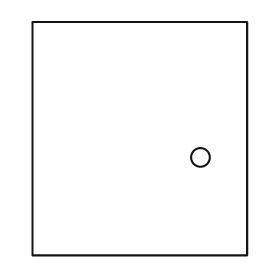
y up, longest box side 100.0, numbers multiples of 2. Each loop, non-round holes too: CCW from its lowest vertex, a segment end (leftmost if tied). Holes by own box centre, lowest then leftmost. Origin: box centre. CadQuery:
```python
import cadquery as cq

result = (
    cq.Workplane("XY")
    .moveTo(-46.0, -50.0)
    .lineTo(46.0, -50.0)
    .lineTo(46.0, 50.0)
    .lineTo(-46.0, 50.0)
    .close()
    .moveTo(26.0, -8.0)
    .circle(4.0)
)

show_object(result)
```